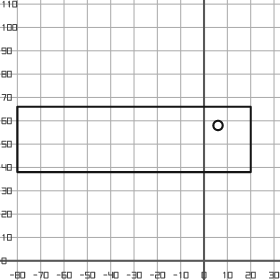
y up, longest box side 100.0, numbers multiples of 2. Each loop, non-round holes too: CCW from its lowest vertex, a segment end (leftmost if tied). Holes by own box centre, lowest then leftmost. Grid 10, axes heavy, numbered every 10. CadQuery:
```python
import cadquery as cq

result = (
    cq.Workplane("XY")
    .moveTo(-80.0, 38.0)
    .lineTo(20.0, 38.0)
    .lineTo(20.0, 66.0)
    .lineTo(-80.0, 66.0)
    .close()
    .moveTo(6.0, 58.0)
    .circle(2.0)
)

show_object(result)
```